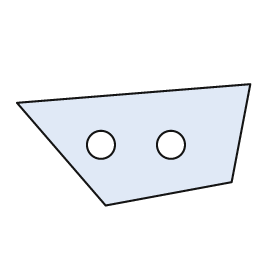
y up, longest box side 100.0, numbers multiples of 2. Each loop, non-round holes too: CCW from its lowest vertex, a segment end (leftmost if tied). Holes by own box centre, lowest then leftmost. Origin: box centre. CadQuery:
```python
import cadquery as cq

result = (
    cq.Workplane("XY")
    .moveTo(-12.0, -26.0)
    .lineTo(42.0, -16.0)
    .lineTo(50.0, 26.0)
    .lineTo(-50.0, 18.0)
    .close()
    .moveTo(-14.0, 0.0)
    .circle(6.0)
    .moveTo(16.0, 0.0)
    .circle(6.0)
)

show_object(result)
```